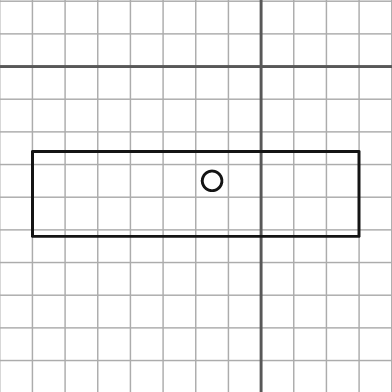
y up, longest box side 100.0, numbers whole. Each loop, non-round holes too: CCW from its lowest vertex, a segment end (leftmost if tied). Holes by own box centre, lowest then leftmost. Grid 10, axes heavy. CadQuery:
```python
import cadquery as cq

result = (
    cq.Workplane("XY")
    .moveTo(-70.0, -52.0)
    .lineTo(30.0, -52.0)
    .lineTo(30.0, -26.0)
    .lineTo(-70.0, -26.0)
    .close()
    .moveTo(-15.0, -35.0)
    .circle(3.0)
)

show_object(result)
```